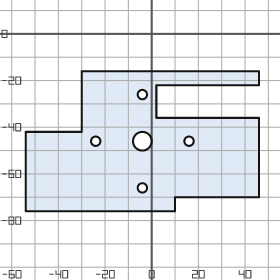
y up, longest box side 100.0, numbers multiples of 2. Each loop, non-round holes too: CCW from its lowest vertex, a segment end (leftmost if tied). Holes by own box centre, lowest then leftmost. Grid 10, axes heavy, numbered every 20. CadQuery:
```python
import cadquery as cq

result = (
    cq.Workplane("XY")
    .moveTo(-54.0, -76.0)
    .lineTo(10.0, -76.0)
    .lineTo(10.0, -70.0)
    .lineTo(46.0, -70.0)
    .lineTo(46.0, -36.0)
    .lineTo(2.0, -36.0)
    .lineTo(2.0, -22.0)
    .lineTo(46.0, -22.0)
    .lineTo(46.0, -16.0)
    .lineTo(-30.0, -16.0)
    .lineTo(-30.0, -42.0)
    .lineTo(-54.0, -42.0)
    .close()
    .moveTo(-4.0, -66.0)
    .circle(2.0)
    .moveTo(-24.0, -46.0)
    .circle(2.0)
    .moveTo(-4.0, -46.0)
    .circle(4.0)
    .moveTo(16.0, -46.0)
    .circle(2.0)
    .moveTo(-4.0, -26.0)
    .circle(2.0)
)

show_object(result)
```